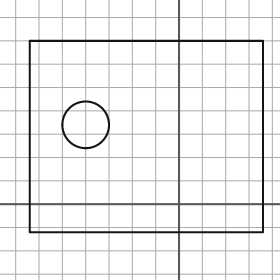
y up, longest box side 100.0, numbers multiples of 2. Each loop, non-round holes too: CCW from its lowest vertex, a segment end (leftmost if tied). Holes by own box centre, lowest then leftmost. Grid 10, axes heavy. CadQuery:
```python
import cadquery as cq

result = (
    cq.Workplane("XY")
    .moveTo(-64.0, -12.0)
    .lineTo(36.0, -12.0)
    .lineTo(36.0, 70.0)
    .lineTo(-64.0, 70.0)
    .close()
    .moveTo(-40.0, 34.0)
    .circle(10.0)
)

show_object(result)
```